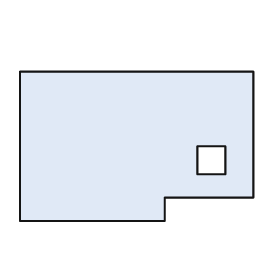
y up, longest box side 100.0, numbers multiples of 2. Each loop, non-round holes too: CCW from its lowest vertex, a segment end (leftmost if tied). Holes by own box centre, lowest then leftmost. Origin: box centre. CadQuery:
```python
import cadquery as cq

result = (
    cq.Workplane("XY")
    .moveTo(-50.0, -32.0)
    .lineTo(12.0, -32.0)
    .lineTo(12.0, -22.0)
    .lineTo(50.0, -22.0)
    .lineTo(50.0, 32.0)
    .lineTo(-50.0, 32.0)
    .close()
    .moveTo(26.0, -12.0)
    .lineTo(38.0, -12.0)
    .lineTo(38.0, 0.0)
    .lineTo(26.0, 0.0)
    .close()
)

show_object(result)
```